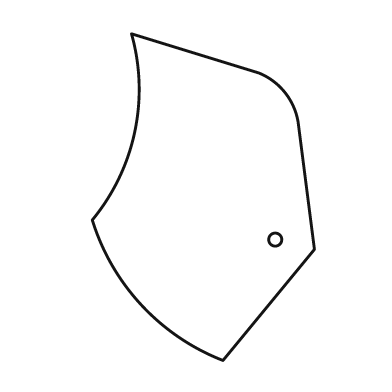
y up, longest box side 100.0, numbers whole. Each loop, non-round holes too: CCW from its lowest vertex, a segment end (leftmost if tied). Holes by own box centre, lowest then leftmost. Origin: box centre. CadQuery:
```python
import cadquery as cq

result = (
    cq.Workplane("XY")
    .moveTo(6.0, -50.0)
    .lineTo(34.0, -16.0)
    .lineTo(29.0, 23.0)
    .threePointArc((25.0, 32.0), (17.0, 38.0))
    .lineTo(-22.0, 50.0)
    .threePointArc((-21.0, 20.0), (-34.0, -7.0))
    .threePointArc((-19.0, -33.0), (6.0, -50.0))
    .close()
    .moveTo(22.0, -13.0)
    .circle(2.0)
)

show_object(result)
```